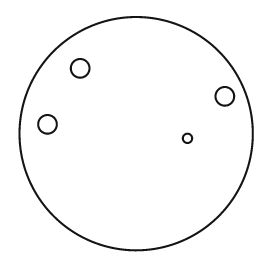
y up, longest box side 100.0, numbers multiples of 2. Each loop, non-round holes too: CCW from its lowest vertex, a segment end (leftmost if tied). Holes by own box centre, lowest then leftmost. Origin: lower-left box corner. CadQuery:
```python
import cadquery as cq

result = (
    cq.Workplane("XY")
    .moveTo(50.0, 50.0)
    .circle(50.0)
    .moveTo(72.0, 48.0)
    .circle(2.0)
    .moveTo(12.0, 54.0)
    .circle(4.0)
    .moveTo(88.0, 66.0)
    .circle(4.0)
    .moveTo(26.0, 78.0)
    .circle(4.0)
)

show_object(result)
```